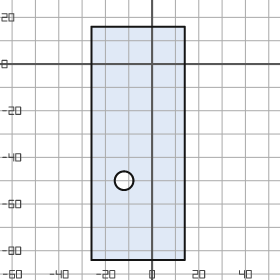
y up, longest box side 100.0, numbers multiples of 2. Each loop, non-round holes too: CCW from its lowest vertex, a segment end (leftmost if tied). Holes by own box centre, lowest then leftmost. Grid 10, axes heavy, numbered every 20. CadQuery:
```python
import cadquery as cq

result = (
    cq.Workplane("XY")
    .moveTo(-26.0, -84.0)
    .lineTo(14.0, -84.0)
    .lineTo(14.0, 16.0)
    .lineTo(-26.0, 16.0)
    .close()
    .moveTo(-12.0, -50.0)
    .circle(4.0)
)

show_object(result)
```